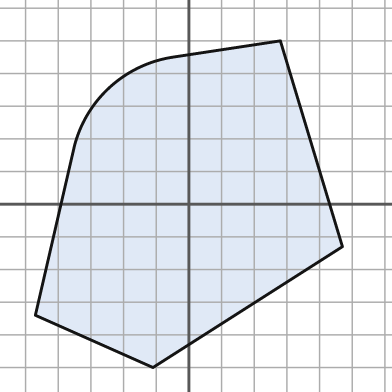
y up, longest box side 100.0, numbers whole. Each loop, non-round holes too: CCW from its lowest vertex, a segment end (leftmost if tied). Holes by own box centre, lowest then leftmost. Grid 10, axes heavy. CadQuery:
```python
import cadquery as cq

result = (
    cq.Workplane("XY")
    .moveTo(-11.0, -50.0)
    .lineTo(47.0, -13.0)
    .lineTo(28.0, 50.0)
    .lineTo(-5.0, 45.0)
    .threePointArc((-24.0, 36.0), (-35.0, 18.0))
    .lineTo(-47.0, -34.0)
    .close()
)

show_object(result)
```